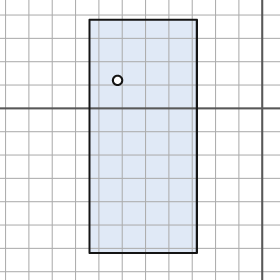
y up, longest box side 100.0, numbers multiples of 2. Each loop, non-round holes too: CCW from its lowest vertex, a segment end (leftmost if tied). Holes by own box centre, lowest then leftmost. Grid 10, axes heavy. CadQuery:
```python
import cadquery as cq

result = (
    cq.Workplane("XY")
    .moveTo(-74.0, -62.0)
    .lineTo(-28.0, -62.0)
    .lineTo(-28.0, 38.0)
    .lineTo(-74.0, 38.0)
    .close()
    .moveTo(-62.0, 12.0)
    .circle(2.0)
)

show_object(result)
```